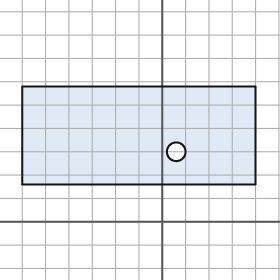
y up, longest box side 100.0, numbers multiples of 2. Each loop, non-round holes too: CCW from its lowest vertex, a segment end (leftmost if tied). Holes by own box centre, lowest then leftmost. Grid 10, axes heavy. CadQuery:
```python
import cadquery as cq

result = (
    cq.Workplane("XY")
    .moveTo(-60.0, 16.0)
    .lineTo(40.0, 16.0)
    .lineTo(40.0, 58.0)
    .lineTo(-60.0, 58.0)
    .close()
    .moveTo(6.0, 30.0)
    .circle(4.0)
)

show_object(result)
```